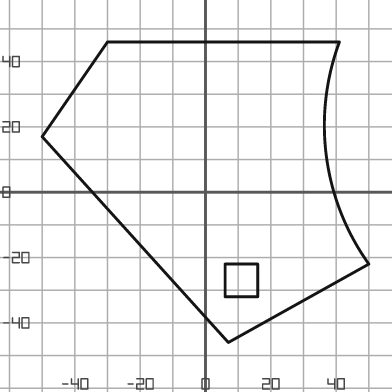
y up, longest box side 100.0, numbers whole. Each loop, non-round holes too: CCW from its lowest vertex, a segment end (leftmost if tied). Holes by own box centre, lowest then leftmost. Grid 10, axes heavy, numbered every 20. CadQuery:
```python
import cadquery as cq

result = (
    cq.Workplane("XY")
    .moveTo(7.0, -46.0)
    .lineTo(50.0, -22.0)
    .threePointArc((37.0, 11.0), (41.0, 46.0))
    .lineTo(-30.0, 46.0)
    .lineTo(-50.0, 17.0)
    .close()
    .moveTo(6.0, -32.0)
    .lineTo(16.0, -32.0)
    .lineTo(16.0, -22.0)
    .lineTo(6.0, -22.0)
    .close()
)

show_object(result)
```